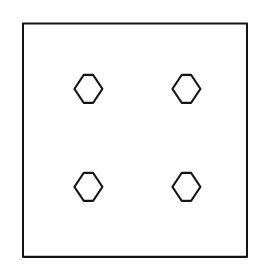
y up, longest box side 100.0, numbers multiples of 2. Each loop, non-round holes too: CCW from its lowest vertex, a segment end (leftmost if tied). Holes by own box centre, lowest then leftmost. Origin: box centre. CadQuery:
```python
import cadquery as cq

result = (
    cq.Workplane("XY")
    .moveTo(-48.0, -50.0)
    .lineTo(48.0, -50.0)
    .lineTo(48.0, 50.0)
    .lineTo(-48.0, 50.0)
    .close()
    .moveTo(-22.0, -26.0)
    .lineTo(-18.0, -26.0)
    .lineTo(-14.0, -20.0)
    .lineTo(-18.0, -14.0)
    .lineTo(-22.0, -14.0)
    .lineTo(-26.0, -20.0)
    .close()
    .moveTo(20.0, -26.0)
    .lineTo(24.0, -26.0)
    .lineTo(28.0, -20.0)
    .lineTo(24.0, -14.0)
    .lineTo(20.0, -14.0)
    .lineTo(16.0, -20.0)
    .close()
    .moveTo(-22.0, 16.0)
    .lineTo(-18.0, 16.0)
    .lineTo(-14.0, 22.0)
    .lineTo(-18.0, 28.0)
    .lineTo(-22.0, 28.0)
    .lineTo(-26.0, 22.0)
    .close()
    .moveTo(20.0, 16.0)
    .lineTo(24.0, 16.0)
    .lineTo(28.0, 22.0)
    .lineTo(24.0, 28.0)
    .lineTo(20.0, 28.0)
    .lineTo(16.0, 22.0)
    .close()
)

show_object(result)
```